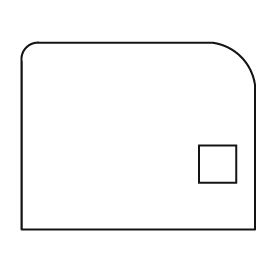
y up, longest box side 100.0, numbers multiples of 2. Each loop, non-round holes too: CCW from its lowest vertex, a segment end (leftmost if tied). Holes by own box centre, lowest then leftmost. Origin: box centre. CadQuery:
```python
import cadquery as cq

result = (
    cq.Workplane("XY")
    .moveTo(-50.0, -40.0)
    .lineTo(50.0, -40.0)
    .lineTo(50.0, 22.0)
    .threePointArc((44.0, 34.0), (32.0, 40.0))
    .lineTo(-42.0, 40.0)
    .threePointArc((-48.0, 38.0), (-50.0, 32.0))
    .close()
    .moveTo(26.0, -20.0)
    .lineTo(42.0, -20.0)
    .lineTo(42.0, -4.0)
    .lineTo(26.0, -4.0)
    .close()
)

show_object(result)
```